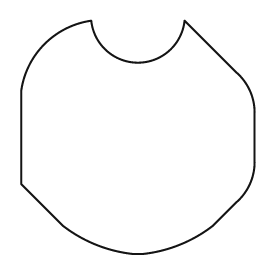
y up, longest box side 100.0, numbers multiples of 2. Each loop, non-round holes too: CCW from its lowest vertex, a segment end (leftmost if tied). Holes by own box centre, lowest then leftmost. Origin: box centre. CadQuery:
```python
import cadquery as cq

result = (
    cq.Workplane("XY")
    .moveTo(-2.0, -50.0)
    .lineTo(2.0, -50.0)
    .threePointArc((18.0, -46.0), (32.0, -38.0))
    .lineTo(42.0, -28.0)
    .threePointArc((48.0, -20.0), (50.0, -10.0))
    .lineTo(50.0, 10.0)
    .threePointArc((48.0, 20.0), (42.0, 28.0))
    .lineTo(20.0, 50.0)
    .threePointArc((0.0, 32.0), (-20.0, 50.0))
    .threePointArc((-40.0, 40.0), (-50.0, 20.0))
    .lineTo(-50.0, -20.0)
    .lineTo(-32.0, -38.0)
    .threePointArc((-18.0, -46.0), (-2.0, -50.0))
    .close()
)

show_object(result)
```